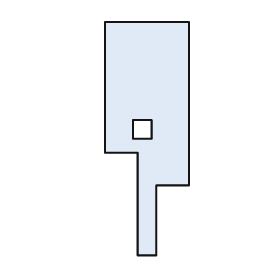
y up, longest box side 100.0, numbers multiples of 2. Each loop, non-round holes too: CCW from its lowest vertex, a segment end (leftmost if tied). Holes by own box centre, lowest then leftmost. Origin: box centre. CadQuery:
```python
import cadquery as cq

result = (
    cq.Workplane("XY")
    .moveTo(-4.0, -50.0)
    .lineTo(4.0, -50.0)
    .lineTo(4.0, -20.0)
    .lineTo(18.0, -20.0)
    .lineTo(18.0, 50.0)
    .lineTo(-18.0, 50.0)
    .lineTo(-18.0, -6.0)
    .lineTo(-4.0, -6.0)
    .close()
    .moveTo(-6.0, 0.0)
    .lineTo(2.0, 0.0)
    .lineTo(2.0, 8.0)
    .lineTo(-6.0, 8.0)
    .close()
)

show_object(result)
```